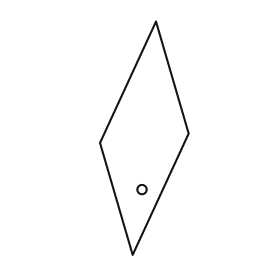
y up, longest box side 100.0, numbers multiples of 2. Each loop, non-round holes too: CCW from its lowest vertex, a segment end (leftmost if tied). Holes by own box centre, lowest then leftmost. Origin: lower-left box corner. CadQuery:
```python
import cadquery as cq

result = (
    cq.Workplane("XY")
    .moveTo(14.0, 0.0)
    .lineTo(38.0, 52.0)
    .lineTo(24.0, 100.0)
    .lineTo(0.0, 48.0)
    .close()
    .moveTo(18.0, 28.0)
    .circle(2.0)
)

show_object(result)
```